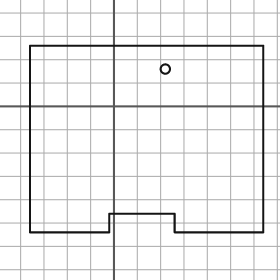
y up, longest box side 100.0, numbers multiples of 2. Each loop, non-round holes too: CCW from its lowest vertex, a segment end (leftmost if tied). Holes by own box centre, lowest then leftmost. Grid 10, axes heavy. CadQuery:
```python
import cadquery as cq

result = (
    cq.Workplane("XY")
    .moveTo(-36.0, -54.0)
    .lineTo(-2.0, -54.0)
    .lineTo(-2.0, -46.0)
    .lineTo(26.0, -46.0)
    .lineTo(26.0, -54.0)
    .lineTo(64.0, -54.0)
    .lineTo(64.0, 26.0)
    .lineTo(-36.0, 26.0)
    .close()
    .moveTo(22.0, 16.0)
    .circle(2.0)
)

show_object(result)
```